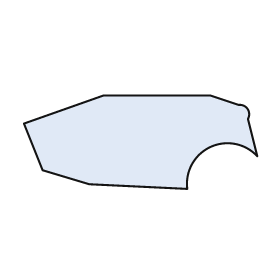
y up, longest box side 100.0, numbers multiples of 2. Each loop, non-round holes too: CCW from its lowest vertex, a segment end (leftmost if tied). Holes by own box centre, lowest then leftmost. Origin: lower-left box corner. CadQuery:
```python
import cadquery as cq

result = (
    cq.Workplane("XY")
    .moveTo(70.0, 0.0)
    .threePointArc((80.0, 18.0), (100.0, 14.0))
    .lineTo(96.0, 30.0)
    .threePointArc((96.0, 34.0), (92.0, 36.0))
    .lineTo(80.0, 40.0)
    .lineTo(34.0, 40.0)
    .lineTo(0.0, 28.0)
    .lineTo(8.0, 8.0)
    .lineTo(28.0, 2.0)
    .close()
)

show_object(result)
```